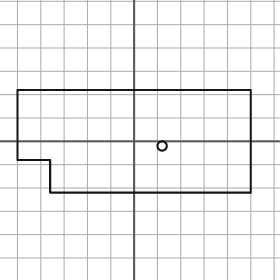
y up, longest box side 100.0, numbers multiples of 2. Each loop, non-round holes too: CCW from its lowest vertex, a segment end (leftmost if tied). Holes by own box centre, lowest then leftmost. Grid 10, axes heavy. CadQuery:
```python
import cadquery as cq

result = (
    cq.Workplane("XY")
    .moveTo(-36.0, -22.0)
    .lineTo(50.0, -22.0)
    .lineTo(50.0, 22.0)
    .lineTo(-50.0, 22.0)
    .lineTo(-50.0, -8.0)
    .lineTo(-36.0, -8.0)
    .close()
    .moveTo(12.0, -2.0)
    .circle(2.0)
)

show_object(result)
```